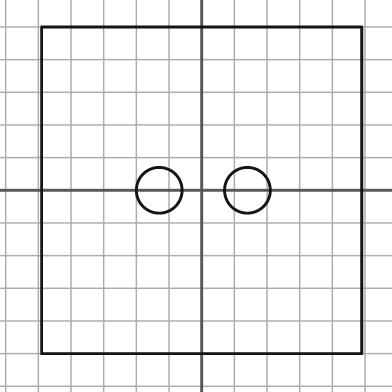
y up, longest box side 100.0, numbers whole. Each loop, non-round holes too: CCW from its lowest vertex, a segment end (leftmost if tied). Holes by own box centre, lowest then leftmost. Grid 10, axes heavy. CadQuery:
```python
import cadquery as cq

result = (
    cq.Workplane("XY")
    .moveTo(-49.0, -50.0)
    .lineTo(49.0, -50.0)
    .lineTo(49.0, 50.0)
    .lineTo(-49.0, 50.0)
    .close()
    .moveTo(-13.0, 0.0)
    .circle(7.0)
    .moveTo(14.0, 0.0)
    .circle(7.0)
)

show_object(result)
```